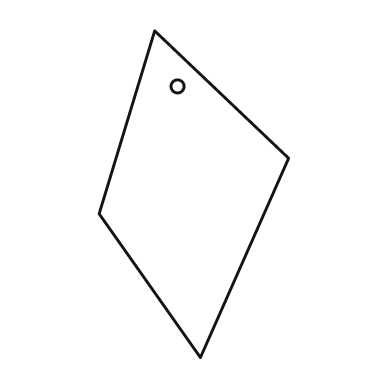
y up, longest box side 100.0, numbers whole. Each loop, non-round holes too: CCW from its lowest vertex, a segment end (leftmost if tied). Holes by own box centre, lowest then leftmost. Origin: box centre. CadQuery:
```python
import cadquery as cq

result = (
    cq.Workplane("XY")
    .moveTo(2.0, -50.0)
    .lineTo(29.0, 11.0)
    .lineTo(-12.0, 50.0)
    .lineTo(-29.0, -6.0)
    .close()
    .moveTo(-5.0, 33.0)
    .circle(2.0)
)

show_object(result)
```